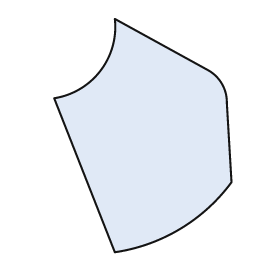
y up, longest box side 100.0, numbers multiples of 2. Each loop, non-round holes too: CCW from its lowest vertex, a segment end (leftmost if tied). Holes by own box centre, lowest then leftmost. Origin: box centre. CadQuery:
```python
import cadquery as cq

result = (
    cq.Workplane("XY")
    .moveTo(-12.0, -50.0)
    .threePointArc((16.0, -40.0), (38.0, -20.0))
    .lineTo(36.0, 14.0)
    .threePointArc((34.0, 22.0), (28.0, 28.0))
    .lineTo(-12.0, 50.0)
    .threePointArc((-18.0, 28.0), (-38.0, 16.0))
    .close()
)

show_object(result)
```